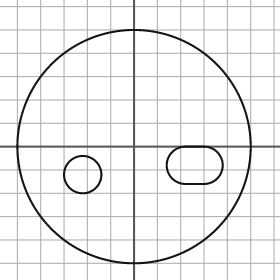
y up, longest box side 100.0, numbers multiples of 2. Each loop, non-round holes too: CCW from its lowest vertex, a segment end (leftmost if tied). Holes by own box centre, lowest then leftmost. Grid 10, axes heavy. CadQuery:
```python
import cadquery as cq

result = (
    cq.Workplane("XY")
    .moveTo(0.0, 0.0)
    .circle(50.0)
    .moveTo(-22.0, -12.0)
    .circle(8.0)
    .moveTo(22.0, -16.0)
    .lineTo(30.0, -16.0)
    .threePointArc((38.0, -8.0), (30.0, 0.0))
    .lineTo(22.0, 0.0)
    .threePointArc((14.0, -8.0), (22.0, -16.0))
    .close()
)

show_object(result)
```